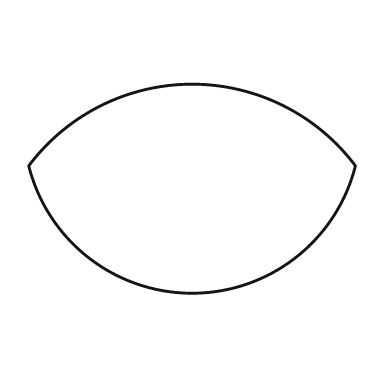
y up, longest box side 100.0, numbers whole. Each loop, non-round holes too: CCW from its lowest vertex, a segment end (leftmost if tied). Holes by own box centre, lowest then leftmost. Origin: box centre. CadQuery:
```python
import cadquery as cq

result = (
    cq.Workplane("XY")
    .moveTo(-50.0, 7.0)
    .threePointArc((0.0, -32.0), (50.0, 7.0))
    .threePointArc((0.0, 32.0), (-50.0, 7.0))
    .close()
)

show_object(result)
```